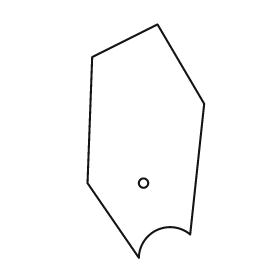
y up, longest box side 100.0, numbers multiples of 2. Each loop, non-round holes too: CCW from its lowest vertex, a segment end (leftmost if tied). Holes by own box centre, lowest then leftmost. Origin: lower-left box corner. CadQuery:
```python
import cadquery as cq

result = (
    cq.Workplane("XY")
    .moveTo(22.0, 0.0)
    .threePointArc((30.0, 12.0), (44.0, 10.0))
    .lineTo(50.0, 66.0)
    .lineTo(30.0, 100.0)
    .lineTo(2.0, 86.0)
    .lineTo(0.0, 32.0)
    .close()
    .moveTo(24.0, 32.0)
    .circle(2.0)
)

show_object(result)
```